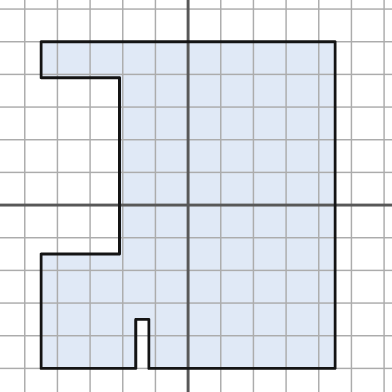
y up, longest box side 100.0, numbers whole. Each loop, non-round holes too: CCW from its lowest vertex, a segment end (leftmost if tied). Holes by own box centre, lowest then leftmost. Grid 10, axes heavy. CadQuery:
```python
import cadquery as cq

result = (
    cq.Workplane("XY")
    .moveTo(-45.0, -50.0)
    .lineTo(-16.0, -50.0)
    .lineTo(-16.0, -35.0)
    .lineTo(-12.0, -35.0)
    .lineTo(-12.0, -50.0)
    .lineTo(45.0, -50.0)
    .lineTo(45.0, 50.0)
    .lineTo(-45.0, 50.0)
    .lineTo(-45.0, 39.0)
    .lineTo(-21.0, 39.0)
    .lineTo(-21.0, -15.0)
    .lineTo(-45.0, -15.0)
    .close()
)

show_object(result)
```